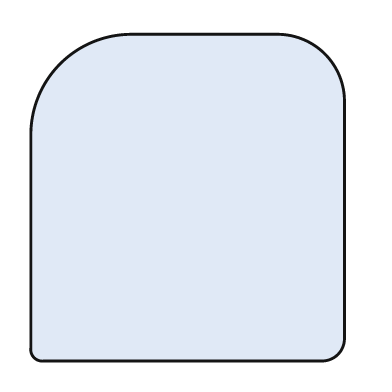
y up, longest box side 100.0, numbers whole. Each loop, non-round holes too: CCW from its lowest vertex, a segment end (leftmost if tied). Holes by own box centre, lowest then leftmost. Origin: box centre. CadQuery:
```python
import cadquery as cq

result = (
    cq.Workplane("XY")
    .moveTo(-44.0, -50.0)
    .lineTo(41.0, -50.0)
    .threePointArc((46.0, -48.0), (48.0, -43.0))
    .lineTo(48.0, 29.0)
    .threePointArc((42.0, 44.0), (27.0, 50.0))
    .lineTo(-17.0, 50.0)
    .threePointArc((-39.0, 41.0), (-48.0, 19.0))
    .lineTo(-48.0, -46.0)
    .threePointArc((-47.0, -49.0), (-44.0, -50.0))
    .close()
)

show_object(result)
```